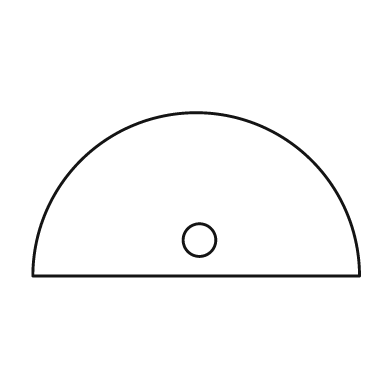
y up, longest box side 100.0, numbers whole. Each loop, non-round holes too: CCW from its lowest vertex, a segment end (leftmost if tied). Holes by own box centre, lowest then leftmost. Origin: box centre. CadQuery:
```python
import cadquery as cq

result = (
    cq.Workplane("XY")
    .moveTo(-50.0, -25.0)
    .lineTo(50.0, -25.0)
    .threePointArc((0.0, 25.0), (-50.0, -25.0))
    .close()
    .moveTo(1.0, -14.0)
    .circle(5.0)
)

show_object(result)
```